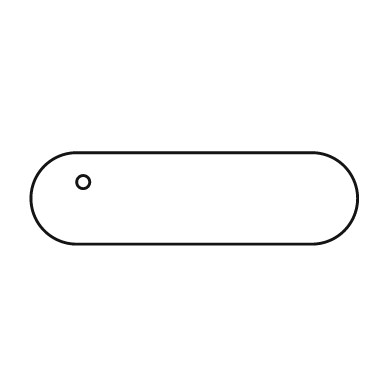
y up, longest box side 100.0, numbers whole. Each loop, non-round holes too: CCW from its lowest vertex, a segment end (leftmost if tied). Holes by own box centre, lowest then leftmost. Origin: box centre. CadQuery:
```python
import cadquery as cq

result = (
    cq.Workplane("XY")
    .moveTo(-36.0, -14.0)
    .lineTo(36.0, -14.0)
    .threePointArc((50.0, 0.0), (36.0, 14.0))
    .lineTo(-36.0, 14.0)
    .threePointArc((-50.0, 0.0), (-36.0, -14.0))
    .close()
    .moveTo(-34.0, 5.0)
    .circle(2.0)
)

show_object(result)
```